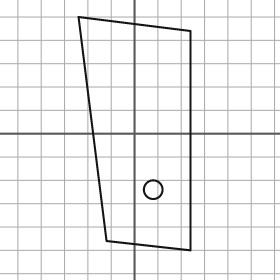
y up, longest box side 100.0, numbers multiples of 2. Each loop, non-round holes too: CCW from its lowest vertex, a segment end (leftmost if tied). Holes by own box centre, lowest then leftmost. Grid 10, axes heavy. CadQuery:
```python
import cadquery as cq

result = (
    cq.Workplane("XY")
    .moveTo(24.0, -50.0)
    .lineTo(24.0, 44.0)
    .lineTo(-24.0, 50.0)
    .lineTo(-12.0, -46.0)
    .close()
    .moveTo(8.0, -24.0)
    .circle(4.0)
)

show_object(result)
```